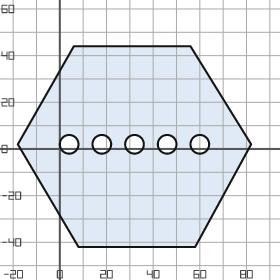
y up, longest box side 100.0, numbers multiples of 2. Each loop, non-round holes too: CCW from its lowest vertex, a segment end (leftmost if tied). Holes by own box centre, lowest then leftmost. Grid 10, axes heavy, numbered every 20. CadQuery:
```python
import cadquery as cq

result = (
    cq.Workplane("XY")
    .moveTo(8.0, -42.0)
    .lineTo(58.0, -42.0)
    .lineTo(82.0, 2.0)
    .lineTo(56.0, 44.0)
    .lineTo(6.0, 44.0)
    .lineTo(-18.0, 2.0)
    .close()
    .moveTo(4.0, 2.0)
    .circle(4.0)
    .moveTo(18.0, 2.0)
    .circle(4.0)
    .moveTo(32.0, 2.0)
    .circle(4.0)
    .moveTo(46.0, 2.0)
    .circle(4.0)
    .moveTo(60.0, 2.0)
    .circle(4.0)
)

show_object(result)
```